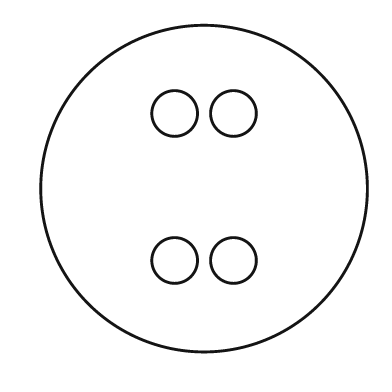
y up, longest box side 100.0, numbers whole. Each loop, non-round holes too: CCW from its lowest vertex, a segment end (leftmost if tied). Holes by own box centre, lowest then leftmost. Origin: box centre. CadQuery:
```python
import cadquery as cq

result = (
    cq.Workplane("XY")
    .moveTo(0.0, 0.0)
    .circle(50.0)
    .moveTo(-9.0, -22.0)
    .circle(7.0)
    .moveTo(9.0, -22.0)
    .circle(7.0)
    .moveTo(-9.0, 23.0)
    .circle(7.0)
    .moveTo(9.0, 23.0)
    .circle(7.0)
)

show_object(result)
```